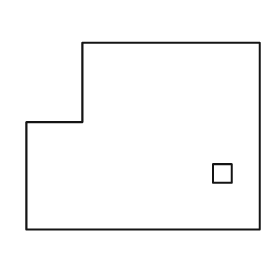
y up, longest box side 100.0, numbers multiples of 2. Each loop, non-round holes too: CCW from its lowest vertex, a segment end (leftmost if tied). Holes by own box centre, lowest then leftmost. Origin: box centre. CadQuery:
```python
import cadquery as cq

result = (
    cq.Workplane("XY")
    .moveTo(-50.0, -40.0)
    .lineTo(50.0, -40.0)
    .lineTo(50.0, 40.0)
    .lineTo(-26.0, 40.0)
    .lineTo(-26.0, 6.0)
    .lineTo(-50.0, 6.0)
    .close()
    .moveTo(30.0, -20.0)
    .lineTo(38.0, -20.0)
    .lineTo(38.0, -12.0)
    .lineTo(30.0, -12.0)
    .close()
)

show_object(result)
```